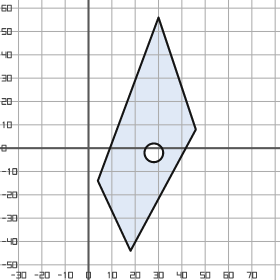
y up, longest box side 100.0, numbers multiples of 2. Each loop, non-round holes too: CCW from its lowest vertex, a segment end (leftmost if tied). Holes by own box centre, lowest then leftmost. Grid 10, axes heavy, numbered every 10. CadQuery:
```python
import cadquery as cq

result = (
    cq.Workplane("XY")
    .moveTo(18.0, -44.0)
    .lineTo(46.0, 8.0)
    .lineTo(30.0, 56.0)
    .lineTo(4.0, -14.0)
    .close()
    .moveTo(28.0, -2.0)
    .circle(4.0)
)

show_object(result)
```